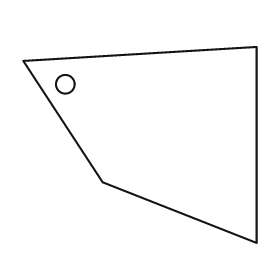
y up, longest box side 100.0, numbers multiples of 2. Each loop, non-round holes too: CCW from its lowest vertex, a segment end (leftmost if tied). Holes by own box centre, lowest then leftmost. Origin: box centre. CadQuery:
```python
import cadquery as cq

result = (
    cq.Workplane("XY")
    .moveTo(50.0, -42.0)
    .lineTo(50.0, 42.0)
    .lineTo(-50.0, 36.0)
    .lineTo(-16.0, -16.0)
    .close()
    .moveTo(-32.0, 26.0)
    .circle(4.0)
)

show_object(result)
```